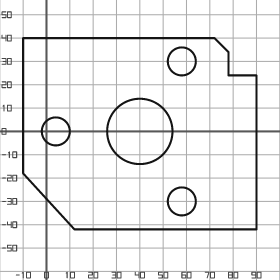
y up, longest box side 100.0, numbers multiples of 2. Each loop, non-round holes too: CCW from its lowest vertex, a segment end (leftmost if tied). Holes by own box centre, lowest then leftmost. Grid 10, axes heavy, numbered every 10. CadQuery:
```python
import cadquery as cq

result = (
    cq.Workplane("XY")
    .moveTo(12.0, -42.0)
    .lineTo(90.0, -42.0)
    .lineTo(90.0, 24.0)
    .lineTo(78.0, 24.0)
    .lineTo(78.0, 34.0)
    .lineTo(72.0, 40.0)
    .lineTo(-10.0, 40.0)
    .lineTo(-10.0, -18.0)
    .close()
    .moveTo(58.0, -30.0)
    .circle(6.0)
    .moveTo(4.0, 0.0)
    .circle(6.0)
    .moveTo(40.0, 0.0)
    .circle(14.0)
    .moveTo(58.0, 30.0)
    .circle(6.0)
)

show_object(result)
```